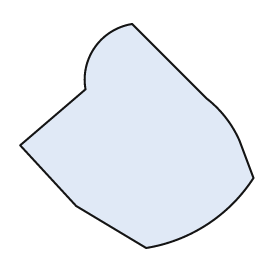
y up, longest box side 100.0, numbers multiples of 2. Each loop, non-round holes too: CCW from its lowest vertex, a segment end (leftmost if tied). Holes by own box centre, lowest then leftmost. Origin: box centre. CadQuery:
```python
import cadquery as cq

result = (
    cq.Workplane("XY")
    .moveTo(4.0, -48.0)
    .threePointArc((30.0, -38.0), (50.0, -18.0))
    .lineTo(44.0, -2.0)
    .threePointArc((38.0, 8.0), (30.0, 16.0))
    .lineTo(-2.0, 48.0)
    .threePointArc((-18.0, 38.0), (-22.0, 20.0))
    .lineTo(-50.0, -4.0)
    .lineTo(-26.0, -30.0)
    .close()
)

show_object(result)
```